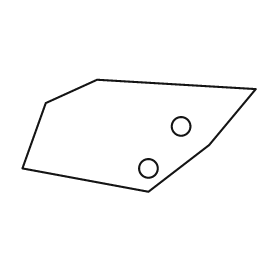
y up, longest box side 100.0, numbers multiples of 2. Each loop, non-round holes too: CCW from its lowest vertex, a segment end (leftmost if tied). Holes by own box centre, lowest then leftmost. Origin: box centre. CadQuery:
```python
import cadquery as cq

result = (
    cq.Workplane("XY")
    .moveTo(4.0, -24.0)
    .lineTo(30.0, -4.0)
    .lineTo(50.0, 20.0)
    .lineTo(-18.0, 24.0)
    .lineTo(-40.0, 14.0)
    .lineTo(-50.0, -14.0)
    .close()
    .moveTo(4.0, -14.0)
    .circle(4.0)
    .moveTo(18.0, 4.0)
    .circle(4.0)
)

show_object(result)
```